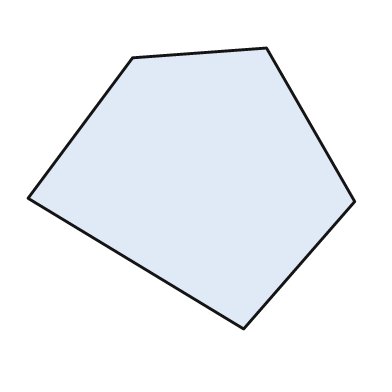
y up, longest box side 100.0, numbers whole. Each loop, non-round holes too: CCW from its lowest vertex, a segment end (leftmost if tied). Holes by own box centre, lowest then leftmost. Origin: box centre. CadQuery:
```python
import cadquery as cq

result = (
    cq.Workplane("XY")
    .moveTo(16.0, -43.0)
    .lineTo(50.0, -4.0)
    .lineTo(23.0, 43.0)
    .lineTo(-18.0, 40.0)
    .lineTo(-50.0, -3.0)
    .close()
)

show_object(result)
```